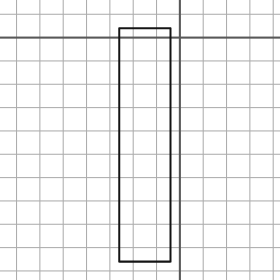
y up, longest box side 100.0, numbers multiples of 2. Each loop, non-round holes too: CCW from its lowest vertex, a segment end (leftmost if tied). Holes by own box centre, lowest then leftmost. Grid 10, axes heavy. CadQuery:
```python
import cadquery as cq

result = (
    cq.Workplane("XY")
    .moveTo(-26.0, -96.0)
    .lineTo(-4.0, -96.0)
    .lineTo(-4.0, 4.0)
    .lineTo(-26.0, 4.0)
    .close()
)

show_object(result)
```